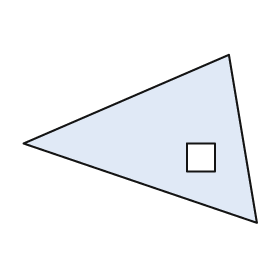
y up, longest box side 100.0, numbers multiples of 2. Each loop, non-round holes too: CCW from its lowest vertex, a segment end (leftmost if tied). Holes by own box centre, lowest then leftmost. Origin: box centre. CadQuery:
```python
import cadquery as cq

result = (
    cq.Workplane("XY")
    .moveTo(50.0, -36.0)
    .lineTo(38.0, 36.0)
    .lineTo(-50.0, -2.0)
    .close()
    .moveTo(20.0, -14.0)
    .lineTo(32.0, -14.0)
    .lineTo(32.0, -2.0)
    .lineTo(20.0, -2.0)
    .close()
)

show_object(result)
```